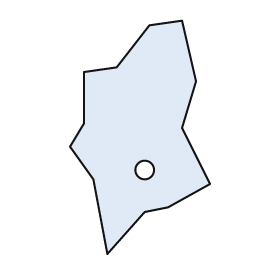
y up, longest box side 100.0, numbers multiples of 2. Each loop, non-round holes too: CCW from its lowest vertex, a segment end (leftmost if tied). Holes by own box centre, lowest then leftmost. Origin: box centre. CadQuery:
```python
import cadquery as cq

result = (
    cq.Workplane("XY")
    .moveTo(-14.0, -50.0)
    .lineTo(2.0, -32.0)
    .lineTo(12.0, -30.0)
    .lineTo(30.0, -20.0)
    .lineTo(18.0, 4.0)
    .lineTo(24.0, 24.0)
    .lineTo(18.0, 50.0)
    .lineTo(4.0, 48.0)
    .lineTo(-10.0, 30.0)
    .lineTo(-24.0, 28.0)
    .lineTo(-24.0, 6.0)
    .lineTo(-30.0, -4.0)
    .lineTo(-20.0, -18.0)
    .close()
    .moveTo(2.0, -14.0)
    .circle(4.0)
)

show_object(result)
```